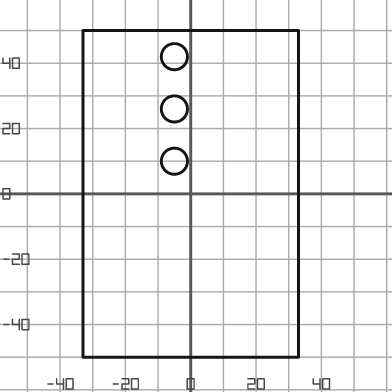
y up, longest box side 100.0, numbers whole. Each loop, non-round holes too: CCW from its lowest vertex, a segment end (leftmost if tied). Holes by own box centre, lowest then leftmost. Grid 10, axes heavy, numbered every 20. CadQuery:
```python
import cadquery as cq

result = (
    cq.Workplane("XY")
    .moveTo(-33.0, -50.0)
    .lineTo(33.0, -50.0)
    .lineTo(33.0, 50.0)
    .lineTo(-33.0, 50.0)
    .close()
    .moveTo(-5.0, 10.0)
    .circle(4.0)
    .moveTo(-5.0, 26.0)
    .circle(4.0)
    .moveTo(-5.0, 42.0)
    .circle(4.0)
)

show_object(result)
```